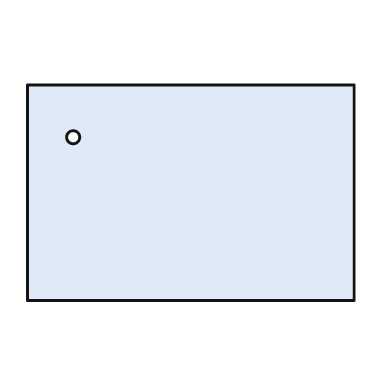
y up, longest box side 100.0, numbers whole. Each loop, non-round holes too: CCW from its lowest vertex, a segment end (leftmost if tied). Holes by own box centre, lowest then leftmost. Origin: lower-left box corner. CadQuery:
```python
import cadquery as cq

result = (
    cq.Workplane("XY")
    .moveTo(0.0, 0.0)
    .lineTo(100.0, 0.0)
    .lineTo(100.0, 66.0)
    .lineTo(0.0, 66.0)
    .close()
    .moveTo(14.0, 50.0)
    .circle(2.0)
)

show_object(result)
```